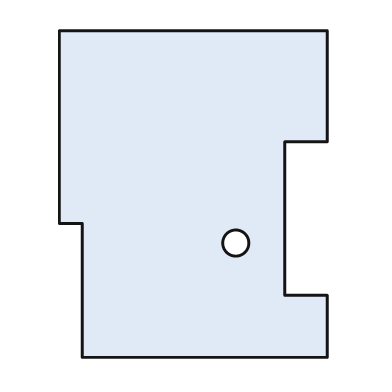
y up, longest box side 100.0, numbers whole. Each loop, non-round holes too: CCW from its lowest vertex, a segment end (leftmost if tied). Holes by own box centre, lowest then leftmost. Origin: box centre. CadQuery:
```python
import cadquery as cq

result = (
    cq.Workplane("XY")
    .moveTo(-34.0, -50.0)
    .lineTo(41.0, -50.0)
    .lineTo(41.0, -31.0)
    .lineTo(28.0, -31.0)
    .lineTo(28.0, 16.0)
    .lineTo(41.0, 16.0)
    .lineTo(41.0, 50.0)
    .lineTo(-41.0, 50.0)
    .lineTo(-41.0, -9.0)
    .lineTo(-34.0, -9.0)
    .close()
    .moveTo(13.0, -15.0)
    .circle(4.0)
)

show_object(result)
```